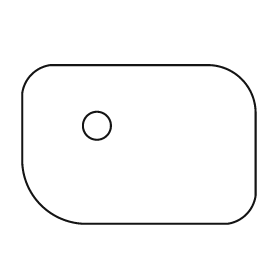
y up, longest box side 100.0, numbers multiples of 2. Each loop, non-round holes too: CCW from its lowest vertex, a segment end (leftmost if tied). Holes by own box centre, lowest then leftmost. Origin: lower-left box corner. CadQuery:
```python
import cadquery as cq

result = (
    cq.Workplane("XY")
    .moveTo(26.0, 0.0)
    .lineTo(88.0, 0.0)
    .threePointArc((96.0, 4.0), (100.0, 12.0))
    .lineTo(100.0, 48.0)
    .threePointArc((94.0, 62.0), (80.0, 68.0))
    .lineTo(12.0, 68.0)
    .threePointArc((4.0, 64.0), (0.0, 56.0))
    .lineTo(0.0, 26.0)
    .threePointArc((8.0, 8.0), (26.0, 0.0))
    .close()
    .moveTo(32.0, 42.0)
    .circle(6.0)
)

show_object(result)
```